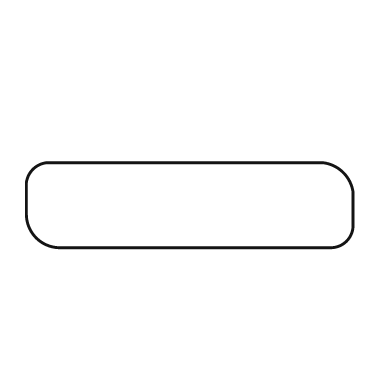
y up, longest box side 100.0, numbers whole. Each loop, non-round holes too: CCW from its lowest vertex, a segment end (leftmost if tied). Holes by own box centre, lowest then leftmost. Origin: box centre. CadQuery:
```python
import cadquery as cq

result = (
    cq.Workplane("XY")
    .moveTo(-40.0, -13.0)
    .lineTo(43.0, -13.0)
    .threePointArc((48.0, -11.0), (50.0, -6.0))
    .lineTo(50.0, 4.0)
    .threePointArc((47.0, 10.0), (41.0, 13.0))
    .lineTo(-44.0, 13.0)
    .threePointArc((-48.0, 11.0), (-50.0, 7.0))
    .lineTo(-50.0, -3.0)
    .threePointArc((-47.0, -10.0), (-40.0, -13.0))
    .close()
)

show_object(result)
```